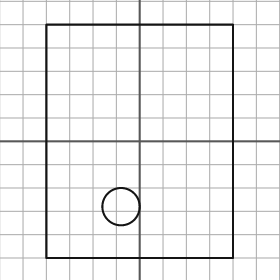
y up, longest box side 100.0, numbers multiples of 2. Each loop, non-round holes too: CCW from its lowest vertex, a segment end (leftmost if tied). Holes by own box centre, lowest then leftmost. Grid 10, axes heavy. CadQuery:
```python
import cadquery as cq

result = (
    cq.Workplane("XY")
    .moveTo(-40.0, -50.0)
    .lineTo(40.0, -50.0)
    .lineTo(40.0, 50.0)
    .lineTo(-40.0, 50.0)
    .close()
    .moveTo(-8.0, -28.0)
    .circle(8.0)
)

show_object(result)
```